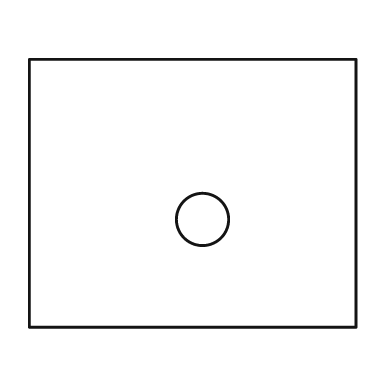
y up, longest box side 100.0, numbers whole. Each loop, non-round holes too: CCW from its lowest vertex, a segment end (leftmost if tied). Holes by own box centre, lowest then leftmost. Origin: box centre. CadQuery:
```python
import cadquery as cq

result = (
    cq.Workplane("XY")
    .moveTo(-50.0, -41.0)
    .lineTo(50.0, -41.0)
    .lineTo(50.0, 41.0)
    .lineTo(-50.0, 41.0)
    .close()
    .moveTo(3.0, -8.0)
    .circle(8.0)
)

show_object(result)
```